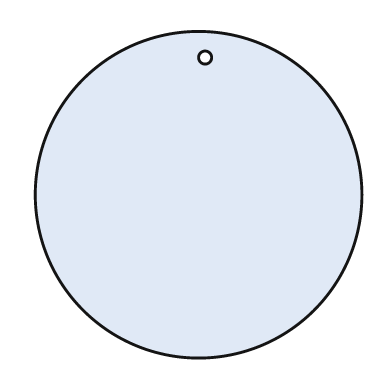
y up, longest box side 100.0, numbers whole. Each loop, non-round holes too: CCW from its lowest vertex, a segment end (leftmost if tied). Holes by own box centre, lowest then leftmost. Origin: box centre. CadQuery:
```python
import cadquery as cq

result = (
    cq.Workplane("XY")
    .moveTo(0.0, 0.0)
    .circle(50.0)
    .moveTo(2.0, 42.0)
    .circle(2.0)
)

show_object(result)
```